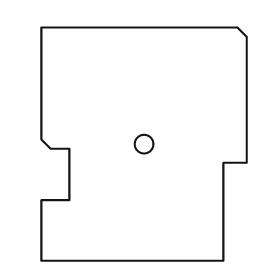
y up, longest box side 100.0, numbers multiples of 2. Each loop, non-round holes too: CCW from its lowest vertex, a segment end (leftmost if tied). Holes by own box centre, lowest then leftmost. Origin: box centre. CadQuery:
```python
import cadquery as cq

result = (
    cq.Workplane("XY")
    .moveTo(-44.0, -50.0)
    .lineTo(34.0, -50.0)
    .lineTo(34.0, -8.0)
    .lineTo(44.0, -8.0)
    .lineTo(44.0, 46.0)
    .lineTo(40.0, 50.0)
    .lineTo(-44.0, 50.0)
    .lineTo(-44.0, 2.0)
    .lineTo(-40.0, -2.0)
    .lineTo(-32.0, -2.0)
    .lineTo(-32.0, -24.0)
    .lineTo(-44.0, -24.0)
    .close()
    .moveTo(0.0, 0.0)
    .circle(4.0)
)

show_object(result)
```